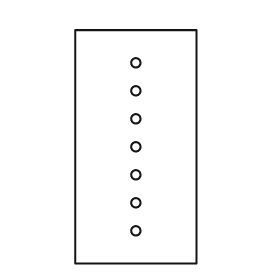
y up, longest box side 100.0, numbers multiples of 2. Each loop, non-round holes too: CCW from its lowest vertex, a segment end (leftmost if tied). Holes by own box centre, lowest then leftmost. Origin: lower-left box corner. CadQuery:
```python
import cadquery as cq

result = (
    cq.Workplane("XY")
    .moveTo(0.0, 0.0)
    .lineTo(52.0, 0.0)
    .lineTo(52.0, 100.0)
    .lineTo(0.0, 100.0)
    .close()
    .moveTo(26.0, 14.0)
    .circle(2.0)
    .moveTo(26.0, 26.0)
    .circle(2.0)
    .moveTo(26.0, 38.0)
    .circle(2.0)
    .moveTo(26.0, 50.0)
    .circle(2.0)
    .moveTo(26.0, 62.0)
    .circle(2.0)
    .moveTo(26.0, 74.0)
    .circle(2.0)
    .moveTo(26.0, 86.0)
    .circle(2.0)
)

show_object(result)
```